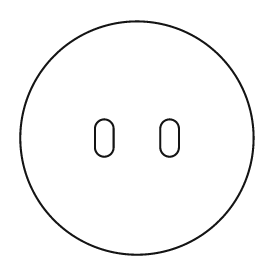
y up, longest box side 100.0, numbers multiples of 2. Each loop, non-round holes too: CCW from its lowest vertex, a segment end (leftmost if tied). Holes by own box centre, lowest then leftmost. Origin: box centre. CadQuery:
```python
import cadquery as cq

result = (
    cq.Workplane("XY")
    .moveTo(0.0, 0.0)
    .circle(50.0)
    .moveTo(-18.0, -4.0)
    .threePointArc((-14.0, -8.0), (-10.0, -4.0))
    .lineTo(-10.0, 4.0)
    .threePointArc((-14.0, 8.0), (-18.0, 4.0))
    .close()
    .moveTo(10.0, -4.0)
    .threePointArc((14.0, -8.0), (18.0, -4.0))
    .lineTo(18.0, 4.0)
    .threePointArc((14.0, 8.0), (10.0, 4.0))
    .close()
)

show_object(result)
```